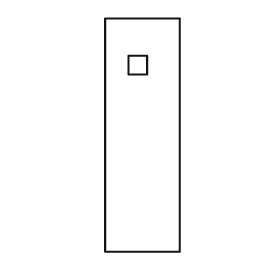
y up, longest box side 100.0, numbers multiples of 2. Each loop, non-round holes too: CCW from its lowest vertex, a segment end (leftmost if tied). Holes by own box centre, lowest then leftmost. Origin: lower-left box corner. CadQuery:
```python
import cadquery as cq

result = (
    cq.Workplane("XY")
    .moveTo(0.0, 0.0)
    .lineTo(32.0, 0.0)
    .lineTo(32.0, 100.0)
    .lineTo(0.0, 100.0)
    .close()
    .moveTo(10.0, 76.0)
    .lineTo(18.0, 76.0)
    .lineTo(18.0, 84.0)
    .lineTo(10.0, 84.0)
    .close()
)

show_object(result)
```